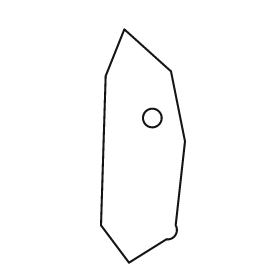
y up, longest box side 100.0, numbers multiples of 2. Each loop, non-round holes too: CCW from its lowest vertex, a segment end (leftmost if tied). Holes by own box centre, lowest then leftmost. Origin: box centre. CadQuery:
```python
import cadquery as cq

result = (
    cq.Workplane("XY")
    .moveTo(-6.0, -50.0)
    .lineTo(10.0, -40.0)
    .threePointArc((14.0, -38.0), (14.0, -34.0))
    .lineTo(18.0, 2.0)
    .lineTo(12.0, 32.0)
    .lineTo(-8.0, 50.0)
    .lineTo(-16.0, 30.0)
    .lineTo(-18.0, -34.0)
    .close()
    .moveTo(4.0, 12.0)
    .circle(4.0)
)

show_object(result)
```